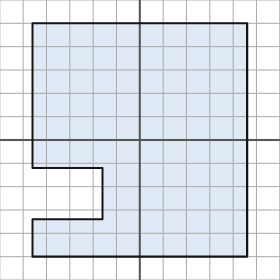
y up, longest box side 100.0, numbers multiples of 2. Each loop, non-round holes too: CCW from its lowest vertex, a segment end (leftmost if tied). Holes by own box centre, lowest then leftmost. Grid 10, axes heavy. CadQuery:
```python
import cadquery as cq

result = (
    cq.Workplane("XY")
    .moveTo(-46.0, -50.0)
    .lineTo(46.0, -50.0)
    .lineTo(46.0, 50.0)
    .lineTo(-46.0, 50.0)
    .lineTo(-46.0, -12.0)
    .lineTo(-16.0, -12.0)
    .lineTo(-16.0, -34.0)
    .lineTo(-46.0, -34.0)
    .close()
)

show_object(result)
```